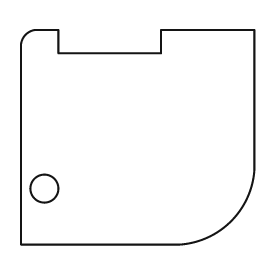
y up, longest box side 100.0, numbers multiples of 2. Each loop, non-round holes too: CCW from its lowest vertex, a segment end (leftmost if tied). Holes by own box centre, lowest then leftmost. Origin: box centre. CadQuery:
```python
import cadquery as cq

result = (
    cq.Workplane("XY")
    .moveTo(-50.0, -46.0)
    .lineTo(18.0, -46.0)
    .threePointArc((40.0, -36.0), (50.0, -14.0))
    .lineTo(50.0, 46.0)
    .lineTo(10.0, 46.0)
    .lineTo(10.0, 36.0)
    .lineTo(-34.0, 36.0)
    .lineTo(-34.0, 46.0)
    .lineTo(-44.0, 46.0)
    .threePointArc((-48.0, 44.0), (-50.0, 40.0))
    .close()
    .moveTo(-40.0, -22.0)
    .circle(6.0)
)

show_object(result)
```